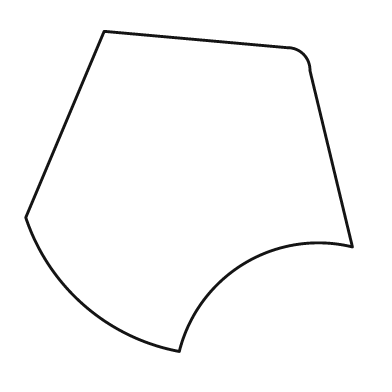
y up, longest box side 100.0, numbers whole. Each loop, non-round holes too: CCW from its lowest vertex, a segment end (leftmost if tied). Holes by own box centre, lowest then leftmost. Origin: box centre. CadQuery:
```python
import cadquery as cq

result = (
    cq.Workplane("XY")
    .moveTo(-3.0, -49.0)
    .threePointArc((17.0, -22.0), (50.0, -17.0))
    .lineTo(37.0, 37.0)
    .threePointArc((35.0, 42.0), (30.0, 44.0))
    .lineTo(-26.0, 49.0)
    .lineTo(-50.0, -8.0)
    .threePointArc((-32.0, -35.0), (-3.0, -49.0))
    .close()
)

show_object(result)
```